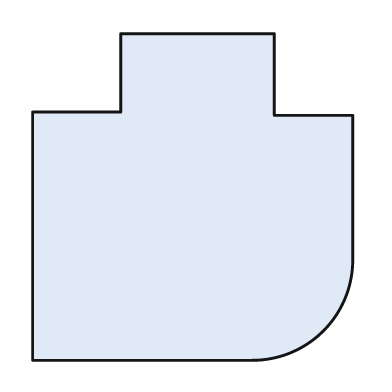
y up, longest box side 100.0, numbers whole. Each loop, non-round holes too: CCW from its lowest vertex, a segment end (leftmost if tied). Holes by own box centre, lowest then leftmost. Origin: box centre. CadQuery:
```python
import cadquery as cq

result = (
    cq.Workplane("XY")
    .moveTo(-49.0, -50.0)
    .lineTo(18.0, -50.0)
    .threePointArc((40.0, -41.0), (49.0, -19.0))
    .lineTo(49.0, 25.0)
    .lineTo(25.0, 25.0)
    .lineTo(25.0, 50.0)
    .lineTo(-22.0, 50.0)
    .lineTo(-22.0, 26.0)
    .lineTo(-49.0, 26.0)
    .close()
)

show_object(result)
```